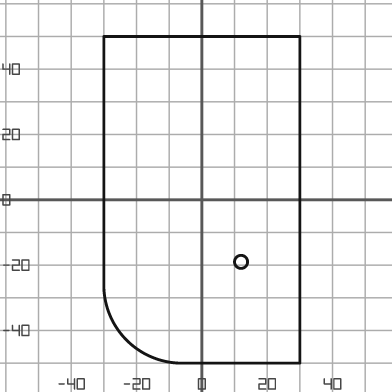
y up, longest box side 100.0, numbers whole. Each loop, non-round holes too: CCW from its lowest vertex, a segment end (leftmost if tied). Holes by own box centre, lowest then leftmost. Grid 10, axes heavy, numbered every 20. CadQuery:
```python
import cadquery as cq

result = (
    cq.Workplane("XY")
    .moveTo(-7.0, -50.0)
    .lineTo(30.0, -50.0)
    .lineTo(30.0, 50.0)
    .lineTo(-30.0, 50.0)
    .lineTo(-30.0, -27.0)
    .threePointArc((-23.0, -43.0), (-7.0, -50.0))
    .close()
    .moveTo(12.0, -19.0)
    .circle(2.0)
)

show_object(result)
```